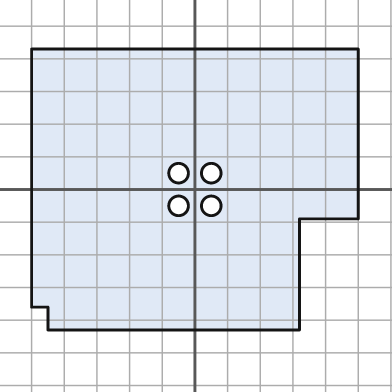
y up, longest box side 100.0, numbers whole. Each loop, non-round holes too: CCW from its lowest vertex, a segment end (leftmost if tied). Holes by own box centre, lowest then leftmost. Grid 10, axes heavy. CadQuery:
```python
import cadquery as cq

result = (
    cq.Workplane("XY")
    .moveTo(-45.0, -43.0)
    .lineTo(32.0, -43.0)
    .lineTo(32.0, -9.0)
    .lineTo(50.0, -9.0)
    .lineTo(50.0, 43.0)
    .lineTo(-50.0, 43.0)
    .lineTo(-50.0, -36.0)
    .lineTo(-45.0, -36.0)
    .close()
    .moveTo(-5.0, -5.0)
    .circle(3.0)
    .moveTo(5.0, -5.0)
    .circle(3.0)
    .moveTo(-5.0, 5.0)
    .circle(3.0)
    .moveTo(5.0, 5.0)
    .circle(3.0)
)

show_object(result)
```